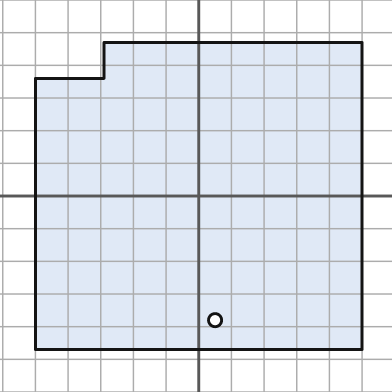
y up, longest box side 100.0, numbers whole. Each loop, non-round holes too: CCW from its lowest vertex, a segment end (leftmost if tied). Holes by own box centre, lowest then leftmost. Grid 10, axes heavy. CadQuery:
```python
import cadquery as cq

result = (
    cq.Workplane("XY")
    .moveTo(-50.0, -47.0)
    .lineTo(50.0, -47.0)
    .lineTo(50.0, 47.0)
    .lineTo(-29.0, 47.0)
    .lineTo(-29.0, 36.0)
    .lineTo(-50.0, 36.0)
    .close()
    .moveTo(5.0, -38.0)
    .circle(2.0)
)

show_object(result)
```